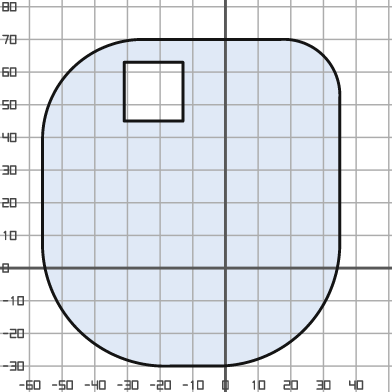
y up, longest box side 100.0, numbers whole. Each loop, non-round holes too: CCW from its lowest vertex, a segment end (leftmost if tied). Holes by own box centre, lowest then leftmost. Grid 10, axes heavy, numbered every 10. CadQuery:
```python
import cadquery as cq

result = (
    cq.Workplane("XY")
    .moveTo(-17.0, -30.0)
    .lineTo(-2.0, -30.0)
    .threePointArc((24.0, -19.0), (35.0, 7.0))
    .lineTo(35.0, 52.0)
    .threePointArc((30.0, 65.0), (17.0, 70.0))
    .lineTo(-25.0, 70.0)
    .threePointArc((-47.0, 61.0), (-56.0, 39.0))
    .lineTo(-56.0, 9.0)
    .threePointArc((-45.0, -19.0), (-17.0, -30.0))
    .close()
    .moveTo(-31.0, 45.0)
    .lineTo(-13.0, 45.0)
    .lineTo(-13.0, 63.0)
    .lineTo(-31.0, 63.0)
    .close()
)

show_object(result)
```